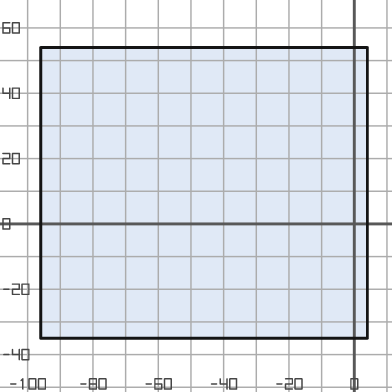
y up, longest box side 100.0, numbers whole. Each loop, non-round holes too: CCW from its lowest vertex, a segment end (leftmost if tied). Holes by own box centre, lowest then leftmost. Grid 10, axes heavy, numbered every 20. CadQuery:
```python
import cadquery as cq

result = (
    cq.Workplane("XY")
    .moveTo(-96.0, -35.0)
    .lineTo(4.0, -35.0)
    .lineTo(4.0, 54.0)
    .lineTo(-96.0, 54.0)
    .close()
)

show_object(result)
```